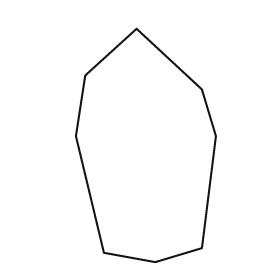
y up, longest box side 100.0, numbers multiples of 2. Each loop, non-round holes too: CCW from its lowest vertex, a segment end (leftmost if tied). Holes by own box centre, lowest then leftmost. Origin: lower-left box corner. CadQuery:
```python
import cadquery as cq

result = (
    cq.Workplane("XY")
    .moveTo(34.0, 0.0)
    .lineTo(54.0, 6.0)
    .lineTo(60.0, 54.0)
    .lineTo(54.0, 74.0)
    .lineTo(26.0, 100.0)
    .lineTo(4.0, 80.0)
    .lineTo(0.0, 54.0)
    .lineTo(12.0, 4.0)
    .close()
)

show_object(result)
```